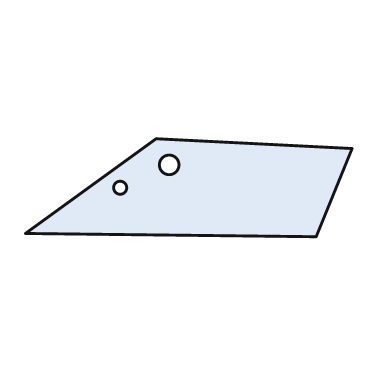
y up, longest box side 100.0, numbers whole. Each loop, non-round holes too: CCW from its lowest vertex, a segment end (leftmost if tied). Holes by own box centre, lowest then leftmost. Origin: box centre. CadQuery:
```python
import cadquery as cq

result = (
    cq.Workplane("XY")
    .moveTo(39.0, -15.0)
    .lineTo(50.0, 12.0)
    .lineTo(-10.0, 15.0)
    .lineTo(-50.0, -14.0)
    .close()
    .moveTo(-21.0, 0.0)
    .circle(2.0)
    .moveTo(-6.0, 7.0)
    .circle(3.0)
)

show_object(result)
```